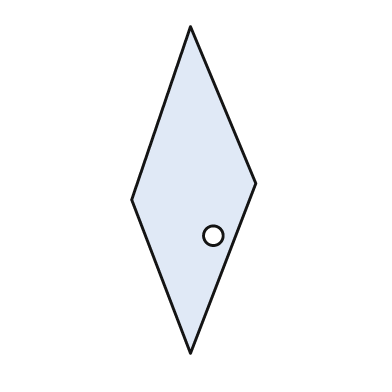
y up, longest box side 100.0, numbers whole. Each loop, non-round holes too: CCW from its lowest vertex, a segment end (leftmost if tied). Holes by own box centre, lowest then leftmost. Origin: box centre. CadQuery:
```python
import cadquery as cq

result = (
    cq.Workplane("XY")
    .moveTo(-1.0, -50.0)
    .lineTo(19.0, 2.0)
    .lineTo(-1.0, 50.0)
    .lineTo(-19.0, -3.0)
    .close()
    .moveTo(6.0, -14.0)
    .circle(3.0)
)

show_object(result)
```